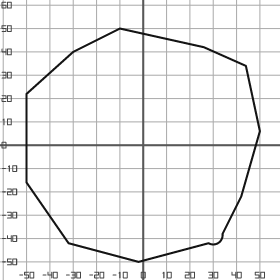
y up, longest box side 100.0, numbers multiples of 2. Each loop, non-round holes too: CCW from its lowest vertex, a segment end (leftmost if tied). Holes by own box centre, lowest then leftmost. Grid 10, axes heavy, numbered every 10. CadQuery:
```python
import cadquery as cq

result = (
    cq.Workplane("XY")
    .moveTo(-2.0, -50.0)
    .lineTo(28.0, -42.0)
    .threePointArc((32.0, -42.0), (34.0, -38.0))
    .lineTo(42.0, -22.0)
    .lineTo(50.0, 6.0)
    .lineTo(44.0, 34.0)
    .lineTo(26.0, 42.0)
    .lineTo(-10.0, 50.0)
    .lineTo(-30.0, 40.0)
    .lineTo(-50.0, 22.0)
    .lineTo(-50.0, -16.0)
    .lineTo(-32.0, -42.0)
    .close()
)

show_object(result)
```